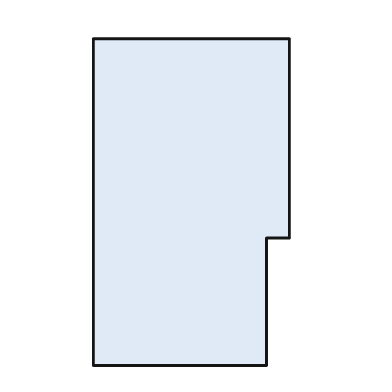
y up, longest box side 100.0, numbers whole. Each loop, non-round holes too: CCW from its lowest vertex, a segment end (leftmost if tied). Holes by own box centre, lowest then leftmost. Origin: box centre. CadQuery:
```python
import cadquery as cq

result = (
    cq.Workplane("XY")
    .moveTo(-30.0, -50.0)
    .lineTo(23.0, -50.0)
    .lineTo(23.0, -11.0)
    .lineTo(30.0, -11.0)
    .lineTo(30.0, 50.0)
    .lineTo(-30.0, 50.0)
    .close()
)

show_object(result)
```